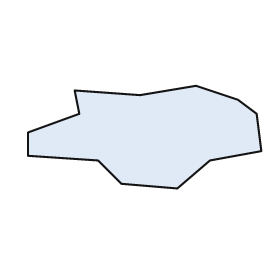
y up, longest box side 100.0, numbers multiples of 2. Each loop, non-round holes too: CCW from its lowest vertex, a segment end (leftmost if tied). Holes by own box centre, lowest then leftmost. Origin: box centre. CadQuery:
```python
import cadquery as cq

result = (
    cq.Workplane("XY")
    .moveTo(14.0, -22.0)
    .lineTo(28.0, -10.0)
    .lineTo(50.0, -6.0)
    .lineTo(48.0, 10.0)
    .lineTo(40.0, 16.0)
    .lineTo(22.0, 22.0)
    .lineTo(-2.0, 18.0)
    .lineTo(-30.0, 20.0)
    .lineTo(-28.0, 10.0)
    .lineTo(-50.0, 2.0)
    .lineTo(-50.0, -8.0)
    .lineTo(-20.0, -10.0)
    .lineTo(-10.0, -20.0)
    .close()
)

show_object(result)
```